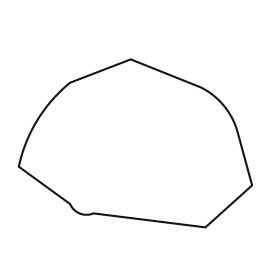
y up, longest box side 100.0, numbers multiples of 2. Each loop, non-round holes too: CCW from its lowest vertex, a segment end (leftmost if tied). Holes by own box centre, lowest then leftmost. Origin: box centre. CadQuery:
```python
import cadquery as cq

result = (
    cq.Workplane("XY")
    .moveTo(30.0, -36.0)
    .lineTo(50.0, -18.0)
    .lineTo(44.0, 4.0)
    .threePointArc((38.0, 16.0), (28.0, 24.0))
    .lineTo(-2.0, 36.0)
    .lineTo(-28.0, 26.0)
    .threePointArc((-42.0, 10.0), (-50.0, -10.0))
    .lineTo(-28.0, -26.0)
    .threePointArc((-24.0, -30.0), (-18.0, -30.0))
    .close()
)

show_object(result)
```